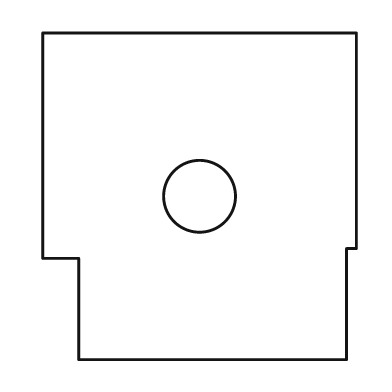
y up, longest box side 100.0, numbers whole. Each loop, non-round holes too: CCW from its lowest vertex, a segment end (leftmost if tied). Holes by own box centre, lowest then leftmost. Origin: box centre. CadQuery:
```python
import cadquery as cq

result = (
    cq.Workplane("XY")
    .moveTo(-37.0, -50.0)
    .lineTo(45.0, -50.0)
    .lineTo(45.0, -16.0)
    .lineTo(48.0, -16.0)
    .lineTo(48.0, 50.0)
    .lineTo(-48.0, 50.0)
    .lineTo(-48.0, -19.0)
    .lineTo(-37.0, -19.0)
    .close()
    .moveTo(0.0, 0.0)
    .circle(11.0)
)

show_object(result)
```